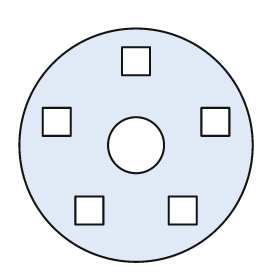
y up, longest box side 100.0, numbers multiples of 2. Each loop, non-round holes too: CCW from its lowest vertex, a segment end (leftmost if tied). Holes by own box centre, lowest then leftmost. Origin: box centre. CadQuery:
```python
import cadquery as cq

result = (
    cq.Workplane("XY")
    .moveTo(0.0, 0.0)
    .circle(50.0)
    .moveTo(-26.0, -34.0)
    .lineTo(-14.0, -34.0)
    .lineTo(-14.0, -22.0)
    .lineTo(-26.0, -22.0)
    .close()
    .moveTo(14.0, -34.0)
    .lineTo(26.0, -34.0)
    .lineTo(26.0, -22.0)
    .lineTo(14.0, -22.0)
    .close()
    .moveTo(0.0, 0.0)
    .circle(12.0)
    .moveTo(-40.0, 4.0)
    .lineTo(-28.0, 4.0)
    .lineTo(-28.0, 16.0)
    .lineTo(-40.0, 16.0)
    .close()
    .moveTo(28.0, 4.0)
    .lineTo(40.0, 4.0)
    .lineTo(40.0, 16.0)
    .lineTo(28.0, 16.0)
    .close()
    .moveTo(-6.0, 30.0)
    .lineTo(6.0, 30.0)
    .lineTo(6.0, 42.0)
    .lineTo(-6.0, 42.0)
    .close()
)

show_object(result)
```